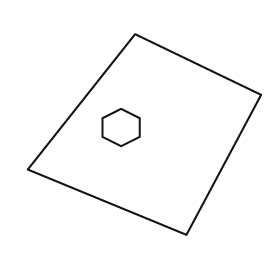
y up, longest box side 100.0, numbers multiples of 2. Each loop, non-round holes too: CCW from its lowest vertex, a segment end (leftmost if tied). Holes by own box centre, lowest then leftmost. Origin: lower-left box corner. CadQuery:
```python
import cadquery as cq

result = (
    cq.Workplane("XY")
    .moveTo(68.0, 0.0)
    .lineTo(100.0, 60.0)
    .lineTo(46.0, 86.0)
    .lineTo(0.0, 28.0)
    .close()
    .moveTo(40.0, 38.0)
    .lineTo(48.0, 42.0)
    .lineTo(48.0, 50.0)
    .lineTo(40.0, 54.0)
    .lineTo(32.0, 50.0)
    .lineTo(32.0, 42.0)
    .close()
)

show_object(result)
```